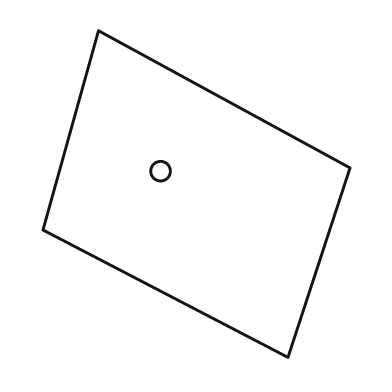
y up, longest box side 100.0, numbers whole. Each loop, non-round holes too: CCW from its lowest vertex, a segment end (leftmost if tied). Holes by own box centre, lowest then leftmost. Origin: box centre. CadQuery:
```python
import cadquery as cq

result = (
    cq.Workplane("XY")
    .moveTo(28.0, -50.0)
    .lineTo(47.0, 8.0)
    .lineTo(-30.0, 50.0)
    .lineTo(-47.0, -11.0)
    .close()
    .moveTo(-11.0, 7.0)
    .circle(3.0)
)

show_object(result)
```